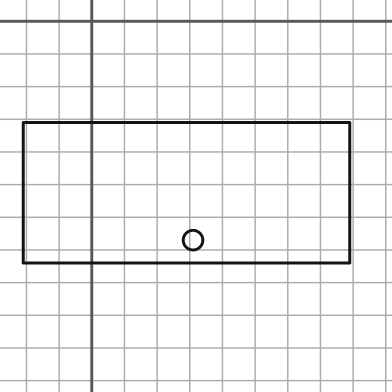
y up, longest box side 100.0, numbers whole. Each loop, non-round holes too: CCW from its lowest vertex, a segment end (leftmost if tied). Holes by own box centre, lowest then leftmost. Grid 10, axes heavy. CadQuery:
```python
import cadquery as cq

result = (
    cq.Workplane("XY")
    .moveTo(-21.0, -74.0)
    .lineTo(79.0, -74.0)
    .lineTo(79.0, -31.0)
    .lineTo(-21.0, -31.0)
    .close()
    .moveTo(31.0, -67.0)
    .circle(3.0)
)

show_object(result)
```